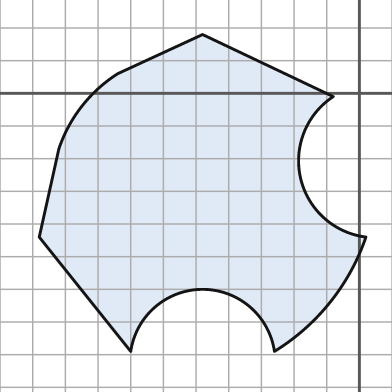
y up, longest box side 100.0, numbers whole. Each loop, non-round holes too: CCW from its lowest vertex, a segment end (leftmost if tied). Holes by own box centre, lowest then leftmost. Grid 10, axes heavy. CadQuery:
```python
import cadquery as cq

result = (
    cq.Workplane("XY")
    .moveTo(-70.0, -79.0)
    .threePointArc((-48.0, -60.0), (-26.0, -79.0))
    .threePointArc((-9.0, -64.0), (2.0, -44.0))
    .threePointArc((-18.0, -26.0), (-8.0, -1.0))
    .lineTo(-48.0, 18.0)
    .lineTo(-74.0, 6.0)
    .threePointArc((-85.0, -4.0), (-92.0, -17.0))
    .lineTo(-98.0, -44.0)
    .close()
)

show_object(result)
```